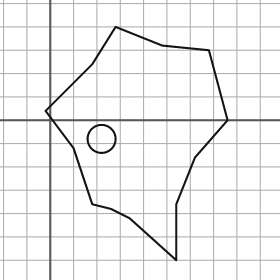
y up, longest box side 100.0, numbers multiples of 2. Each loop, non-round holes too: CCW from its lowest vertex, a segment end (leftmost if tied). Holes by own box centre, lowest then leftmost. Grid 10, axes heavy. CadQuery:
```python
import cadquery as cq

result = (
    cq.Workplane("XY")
    .moveTo(54.0, -60.0)
    .lineTo(54.0, -36.0)
    .lineTo(62.0, -16.0)
    .lineTo(76.0, 0.0)
    .lineTo(68.0, 30.0)
    .lineTo(48.0, 32.0)
    .lineTo(28.0, 40.0)
    .lineTo(18.0, 24.0)
    .lineTo(-2.0, 4.0)
    .lineTo(10.0, -12.0)
    .lineTo(18.0, -36.0)
    .lineTo(26.0, -38.0)
    .lineTo(34.0, -42.0)
    .close()
    .moveTo(22.0, -8.0)
    .circle(6.0)
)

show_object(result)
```